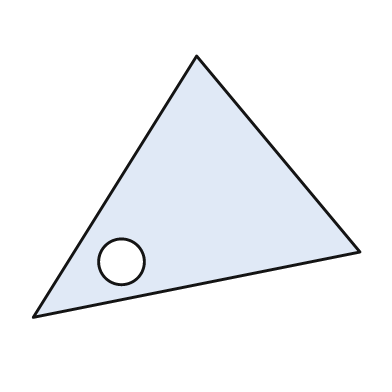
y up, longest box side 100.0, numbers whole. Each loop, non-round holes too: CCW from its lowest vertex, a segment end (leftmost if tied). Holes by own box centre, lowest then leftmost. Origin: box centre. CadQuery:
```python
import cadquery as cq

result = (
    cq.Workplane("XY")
    .moveTo(-50.0, -40.0)
    .lineTo(50.0, -20.0)
    .lineTo(0.0, 40.0)
    .close()
    .moveTo(-23.0, -23.0)
    .circle(7.0)
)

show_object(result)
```